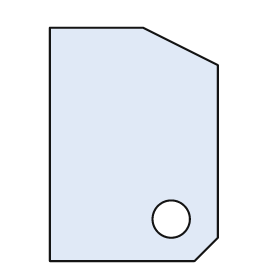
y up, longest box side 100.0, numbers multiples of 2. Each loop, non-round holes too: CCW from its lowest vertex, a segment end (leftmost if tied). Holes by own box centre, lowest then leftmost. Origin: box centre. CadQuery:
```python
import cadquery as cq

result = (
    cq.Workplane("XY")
    .moveTo(-36.0, -50.0)
    .lineTo(26.0, -50.0)
    .lineTo(36.0, -40.0)
    .lineTo(36.0, 34.0)
    .lineTo(4.0, 50.0)
    .lineTo(-36.0, 50.0)
    .close()
    .moveTo(16.0, -32.0)
    .circle(8.0)
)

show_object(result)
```